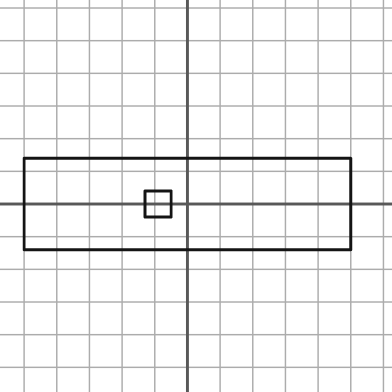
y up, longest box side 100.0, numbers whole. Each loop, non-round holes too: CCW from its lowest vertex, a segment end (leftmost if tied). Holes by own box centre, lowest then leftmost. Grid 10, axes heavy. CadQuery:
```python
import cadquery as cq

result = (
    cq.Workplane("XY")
    .moveTo(-50.0, -14.0)
    .lineTo(50.0, -14.0)
    .lineTo(50.0, 14.0)
    .lineTo(-50.0, 14.0)
    .close()
    .moveTo(-13.0, -4.0)
    .lineTo(-5.0, -4.0)
    .lineTo(-5.0, 4.0)
    .lineTo(-13.0, 4.0)
    .close()
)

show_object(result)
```